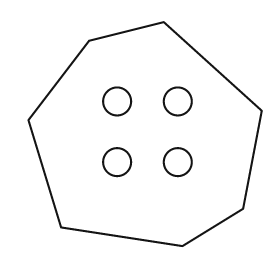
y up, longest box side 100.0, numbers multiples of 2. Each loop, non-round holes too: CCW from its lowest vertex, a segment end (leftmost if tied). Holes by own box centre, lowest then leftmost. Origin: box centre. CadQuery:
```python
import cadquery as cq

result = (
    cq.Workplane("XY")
    .moveTo(16.0, -48.0)
    .lineTo(42.0, -32.0)
    .lineTo(50.0, 10.0)
    .lineTo(8.0, 48.0)
    .lineTo(-24.0, 40.0)
    .lineTo(-50.0, 6.0)
    .lineTo(-36.0, -40.0)
    .close()
    .moveTo(-12.0, -12.0)
    .circle(6.0)
    .moveTo(14.0, -12.0)
    .circle(6.0)
    .moveTo(-12.0, 14.0)
    .circle(6.0)
    .moveTo(14.0, 14.0)
    .circle(6.0)
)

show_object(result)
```